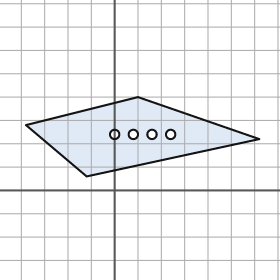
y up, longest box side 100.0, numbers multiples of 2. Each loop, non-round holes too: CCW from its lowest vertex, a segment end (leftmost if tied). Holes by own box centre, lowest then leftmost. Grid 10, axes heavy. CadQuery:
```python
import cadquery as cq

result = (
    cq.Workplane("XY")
    .moveTo(-12.0, 6.0)
    .lineTo(62.0, 22.0)
    .lineTo(10.0, 40.0)
    .lineTo(-38.0, 28.0)
    .close()
    .moveTo(0.0, 24.0)
    .circle(2.0)
    .moveTo(8.0, 24.0)
    .circle(2.0)
    .moveTo(16.0, 24.0)
    .circle(2.0)
    .moveTo(24.0, 24.0)
    .circle(2.0)
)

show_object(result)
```